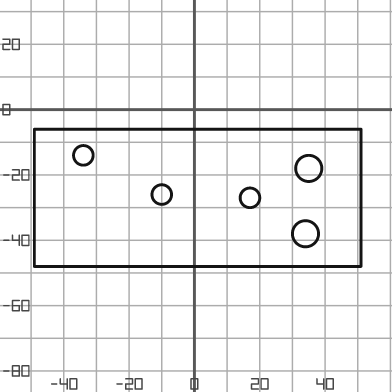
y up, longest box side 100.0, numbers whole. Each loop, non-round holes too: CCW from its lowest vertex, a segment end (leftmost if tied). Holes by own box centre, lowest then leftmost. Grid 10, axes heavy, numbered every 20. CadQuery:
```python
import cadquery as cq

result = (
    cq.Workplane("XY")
    .moveTo(-49.0, -48.0)
    .lineTo(51.0, -48.0)
    .lineTo(51.0, -6.0)
    .lineTo(-49.0, -6.0)
    .close()
    .moveTo(34.0, -38.0)
    .circle(4.0)
    .moveTo(17.0, -27.0)
    .circle(3.0)
    .moveTo(-10.0, -26.0)
    .circle(3.0)
    .moveTo(35.0, -18.0)
    .circle(4.0)
    .moveTo(-34.0, -14.0)
    .circle(3.0)
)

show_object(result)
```